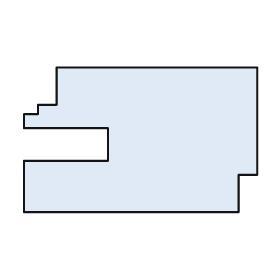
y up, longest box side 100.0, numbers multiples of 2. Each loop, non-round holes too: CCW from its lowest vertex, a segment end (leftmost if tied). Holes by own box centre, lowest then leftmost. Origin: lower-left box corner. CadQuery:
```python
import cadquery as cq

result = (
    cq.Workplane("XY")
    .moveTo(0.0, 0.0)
    .lineTo(92.0, 0.0)
    .lineTo(92.0, 16.0)
    .lineTo(100.0, 16.0)
    .lineTo(100.0, 62.0)
    .lineTo(14.0, 62.0)
    .lineTo(14.0, 46.0)
    .lineTo(6.0, 46.0)
    .lineTo(6.0, 42.0)
    .lineTo(0.0, 42.0)
    .lineTo(0.0, 36.0)
    .lineTo(36.0, 36.0)
    .lineTo(36.0, 22.0)
    .lineTo(0.0, 22.0)
    .close()
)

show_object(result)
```